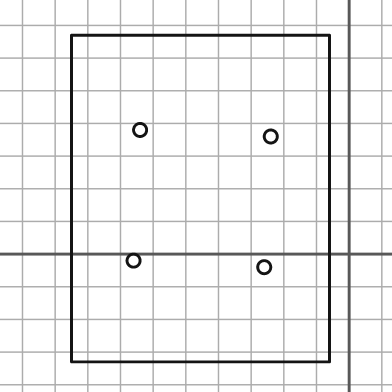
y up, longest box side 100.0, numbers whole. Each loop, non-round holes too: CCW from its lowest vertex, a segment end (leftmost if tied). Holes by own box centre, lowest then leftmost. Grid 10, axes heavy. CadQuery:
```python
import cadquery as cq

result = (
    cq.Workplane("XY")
    .moveTo(-85.0, -33.0)
    .lineTo(-6.0, -33.0)
    .lineTo(-6.0, 67.0)
    .lineTo(-85.0, 67.0)
    .close()
    .moveTo(-26.0, -4.0)
    .circle(2.0)
    .moveTo(-66.0, -2.0)
    .circle(2.0)
    .moveTo(-24.0, 36.0)
    .circle(2.0)
    .moveTo(-64.0, 38.0)
    .circle(2.0)
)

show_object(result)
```